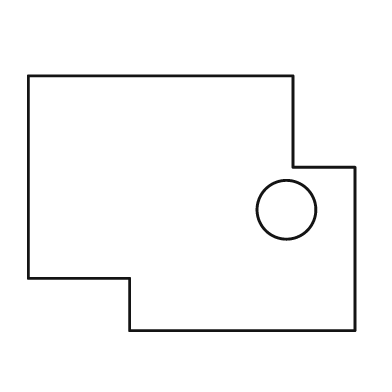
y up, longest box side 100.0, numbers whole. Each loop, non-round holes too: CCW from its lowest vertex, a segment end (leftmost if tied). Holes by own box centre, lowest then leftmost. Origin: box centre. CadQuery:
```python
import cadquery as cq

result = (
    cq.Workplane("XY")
    .moveTo(-19.0, -39.0)
    .lineTo(50.0, -39.0)
    .lineTo(50.0, 11.0)
    .lineTo(31.0, 11.0)
    .lineTo(31.0, 39.0)
    .lineTo(-50.0, 39.0)
    .lineTo(-50.0, -23.0)
    .lineTo(-19.0, -23.0)
    .close()
    .moveTo(29.0, -2.0)
    .circle(9.0)
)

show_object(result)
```